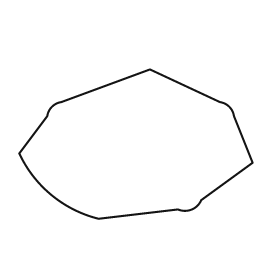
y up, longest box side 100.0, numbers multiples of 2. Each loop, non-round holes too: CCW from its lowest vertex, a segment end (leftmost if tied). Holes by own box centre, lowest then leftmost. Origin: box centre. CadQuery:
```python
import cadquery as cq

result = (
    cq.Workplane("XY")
    .moveTo(-16.0, -32.0)
    .lineTo(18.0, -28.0)
    .threePointArc((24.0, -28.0), (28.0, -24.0))
    .lineTo(50.0, -8.0)
    .lineTo(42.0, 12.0)
    .threePointArc((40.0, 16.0), (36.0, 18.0))
    .lineTo(6.0, 32.0)
    .lineTo(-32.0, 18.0)
    .threePointArc((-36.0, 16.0), (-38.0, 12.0))
    .lineTo(-50.0, -4.0)
    .threePointArc((-36.0, -22.0), (-16.0, -32.0))
    .close()
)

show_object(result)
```